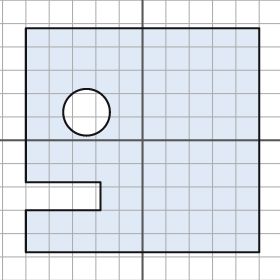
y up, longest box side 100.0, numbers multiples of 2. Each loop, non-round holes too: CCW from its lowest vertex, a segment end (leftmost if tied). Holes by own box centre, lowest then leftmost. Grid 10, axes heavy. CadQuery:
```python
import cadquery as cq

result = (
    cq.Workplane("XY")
    .moveTo(-50.0, -48.0)
    .lineTo(50.0, -48.0)
    .lineTo(50.0, 48.0)
    .lineTo(-50.0, 48.0)
    .lineTo(-50.0, -18.0)
    .lineTo(-18.0, -18.0)
    .lineTo(-18.0, -30.0)
    .lineTo(-50.0, -30.0)
    .close()
    .moveTo(-24.0, 12.0)
    .circle(10.0)
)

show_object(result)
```